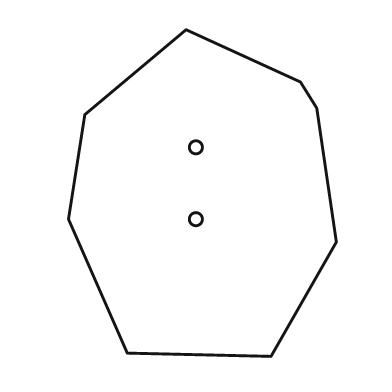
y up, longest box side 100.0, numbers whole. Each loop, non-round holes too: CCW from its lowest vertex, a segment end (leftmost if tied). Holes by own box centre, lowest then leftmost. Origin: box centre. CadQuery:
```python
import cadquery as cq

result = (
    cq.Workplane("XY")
    .moveTo(21.0, -50.0)
    .lineTo(41.0, -15.0)
    .lineTo(35.0, 26.0)
    .lineTo(30.0, 34.0)
    .lineTo(-5.0, 50.0)
    .lineTo(-36.0, 24.0)
    .lineTo(-41.0, -8.0)
    .lineTo(-23.0, -49.0)
    .close()
    .moveTo(-2.0, -8.0)
    .circle(2.0)
    .moveTo(-2.0, 14.0)
    .circle(2.0)
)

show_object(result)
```